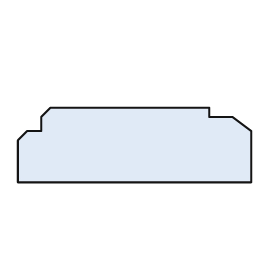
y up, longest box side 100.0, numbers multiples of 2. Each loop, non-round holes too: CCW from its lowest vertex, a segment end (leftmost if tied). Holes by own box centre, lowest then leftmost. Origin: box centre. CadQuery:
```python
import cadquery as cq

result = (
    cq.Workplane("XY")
    .moveTo(-50.0, -16.0)
    .lineTo(50.0, -16.0)
    .lineTo(50.0, 6.0)
    .lineTo(42.0, 12.0)
    .lineTo(32.0, 12.0)
    .lineTo(32.0, 16.0)
    .lineTo(-36.0, 16.0)
    .lineTo(-40.0, 12.0)
    .lineTo(-40.0, 6.0)
    .lineTo(-46.0, 6.0)
    .lineTo(-50.0, 2.0)
    .close()
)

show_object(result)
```